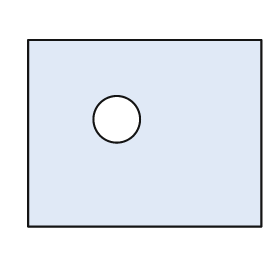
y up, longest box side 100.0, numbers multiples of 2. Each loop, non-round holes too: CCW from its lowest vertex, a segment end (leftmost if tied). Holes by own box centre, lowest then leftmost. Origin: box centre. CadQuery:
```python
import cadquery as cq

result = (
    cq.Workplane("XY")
    .moveTo(-50.0, -40.0)
    .lineTo(50.0, -40.0)
    .lineTo(50.0, 40.0)
    .lineTo(-50.0, 40.0)
    .close()
    .moveTo(-12.0, 6.0)
    .circle(10.0)
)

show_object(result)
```